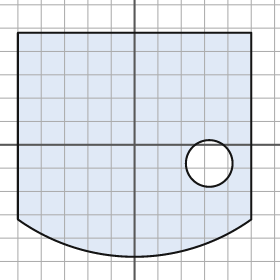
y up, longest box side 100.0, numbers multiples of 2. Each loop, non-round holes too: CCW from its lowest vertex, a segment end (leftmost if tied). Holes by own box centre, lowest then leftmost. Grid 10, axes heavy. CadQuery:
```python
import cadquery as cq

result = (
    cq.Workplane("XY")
    .moveTo(-50.0, -32.0)
    .threePointArc((0.0, -48.0), (50.0, -32.0))
    .lineTo(50.0, 48.0)
    .lineTo(-50.0, 48.0)
    .close()
    .moveTo(32.0, -8.0)
    .circle(10.0)
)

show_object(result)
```